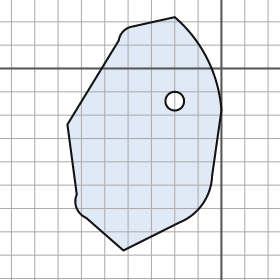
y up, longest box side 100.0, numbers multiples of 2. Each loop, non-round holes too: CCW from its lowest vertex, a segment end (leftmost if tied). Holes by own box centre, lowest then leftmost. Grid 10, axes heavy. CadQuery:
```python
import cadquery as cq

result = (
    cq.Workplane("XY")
    .moveTo(-42.0, -78.0)
    .lineTo(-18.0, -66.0)
    .threePointArc((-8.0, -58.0), (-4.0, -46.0))
    .lineTo(0.0, -18.0)
    .threePointArc((-6.0, 4.0), (-20.0, 22.0))
    .lineTo(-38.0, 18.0)
    .threePointArc((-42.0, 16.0), (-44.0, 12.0))
    .lineTo(-66.0, -24.0)
    .lineTo(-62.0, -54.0)
    .threePointArc((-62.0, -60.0), (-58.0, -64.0))
    .close()
    .moveTo(-20.0, -14.0)
    .circle(4.0)
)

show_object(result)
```